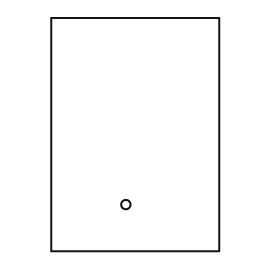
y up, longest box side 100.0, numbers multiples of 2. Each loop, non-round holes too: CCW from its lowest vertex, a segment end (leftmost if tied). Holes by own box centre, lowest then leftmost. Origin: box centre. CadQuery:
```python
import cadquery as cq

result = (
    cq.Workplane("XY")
    .moveTo(-36.0, -50.0)
    .lineTo(36.0, -50.0)
    .lineTo(36.0, 50.0)
    .lineTo(-36.0, 50.0)
    .close()
    .moveTo(-4.0, -30.0)
    .circle(2.0)
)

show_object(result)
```